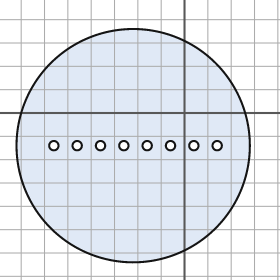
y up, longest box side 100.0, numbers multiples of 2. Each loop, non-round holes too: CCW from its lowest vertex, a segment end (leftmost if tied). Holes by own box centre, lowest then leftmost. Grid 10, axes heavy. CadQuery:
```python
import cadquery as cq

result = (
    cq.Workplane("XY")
    .moveTo(-22.0, -14.0)
    .circle(50.0)
    .moveTo(-56.0, -14.0)
    .circle(2.0)
    .moveTo(-46.0, -14.0)
    .circle(2.0)
    .moveTo(-36.0, -14.0)
    .circle(2.0)
    .moveTo(-26.0, -14.0)
    .circle(2.0)
    .moveTo(-16.0, -14.0)
    .circle(2.0)
    .moveTo(-6.0, -14.0)
    .circle(2.0)
    .moveTo(4.0, -14.0)
    .circle(2.0)
    .moveTo(14.0, -14.0)
    .circle(2.0)
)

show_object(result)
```